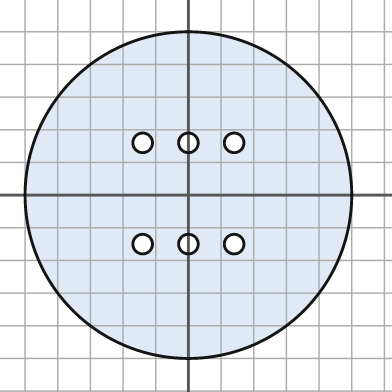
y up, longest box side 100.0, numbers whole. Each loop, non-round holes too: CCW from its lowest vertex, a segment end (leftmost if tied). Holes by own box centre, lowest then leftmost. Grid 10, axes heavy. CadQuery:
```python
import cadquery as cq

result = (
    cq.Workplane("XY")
    .moveTo(0.0, 0.0)
    .circle(50.0)
    .moveTo(-14.0, -15.0)
    .circle(3.0)
    .moveTo(0.0, -15.0)
    .circle(3.0)
    .moveTo(14.0, -15.0)
    .circle(3.0)
    .moveTo(-14.0, 16.0)
    .circle(3.0)
    .moveTo(0.0, 16.0)
    .circle(3.0)
    .moveTo(14.0, 16.0)
    .circle(3.0)
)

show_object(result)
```